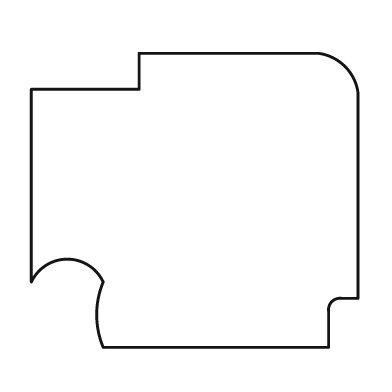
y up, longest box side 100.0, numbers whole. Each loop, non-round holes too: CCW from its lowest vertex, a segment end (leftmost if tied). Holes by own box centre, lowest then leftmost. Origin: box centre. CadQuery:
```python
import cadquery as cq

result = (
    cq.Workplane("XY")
    .moveTo(-28.0, -45.0)
    .lineTo(41.0, -45.0)
    .lineTo(41.0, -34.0)
    .threePointArc((42.0, -31.0), (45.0, -30.0))
    .lineTo(50.0, -30.0)
    .lineTo(50.0, 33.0)
    .threePointArc((46.0, 41.0), (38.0, 45.0))
    .lineTo(-17.0, 45.0)
    .lineTo(-17.0, 34.0)
    .lineTo(-50.0, 34.0)
    .lineTo(-50.0, -25.0)
    .threePointArc((-39.0, -18.0), (-28.0, -25.0))
    .threePointArc((-30.0, -35.0), (-28.0, -45.0))
    .close()
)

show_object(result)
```